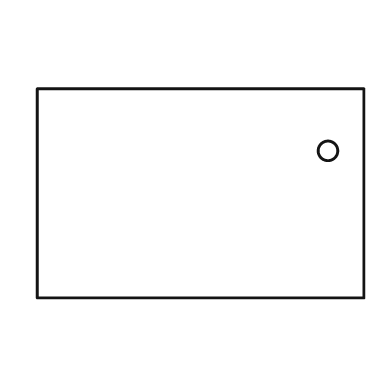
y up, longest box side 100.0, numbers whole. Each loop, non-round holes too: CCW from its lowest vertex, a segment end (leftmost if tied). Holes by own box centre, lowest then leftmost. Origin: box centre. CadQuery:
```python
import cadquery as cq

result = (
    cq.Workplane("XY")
    .moveTo(-50.0, -32.0)
    .lineTo(50.0, -32.0)
    .lineTo(50.0, 32.0)
    .lineTo(-50.0, 32.0)
    .close()
    .moveTo(39.0, 13.0)
    .circle(3.0)
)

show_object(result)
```